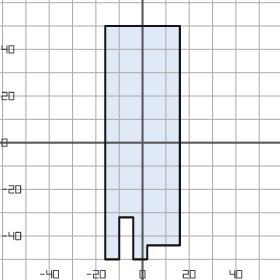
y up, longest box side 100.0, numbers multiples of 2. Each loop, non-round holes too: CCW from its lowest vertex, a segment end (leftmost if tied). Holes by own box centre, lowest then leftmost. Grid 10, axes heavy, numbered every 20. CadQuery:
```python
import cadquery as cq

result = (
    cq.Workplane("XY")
    .moveTo(-16.0, -50.0)
    .lineTo(-10.0, -50.0)
    .lineTo(-10.0, -32.0)
    .lineTo(-4.0, -32.0)
    .lineTo(-4.0, -50.0)
    .lineTo(2.0, -50.0)
    .lineTo(2.0, -44.0)
    .lineTo(16.0, -44.0)
    .lineTo(16.0, 50.0)
    .lineTo(-16.0, 50.0)
    .close()
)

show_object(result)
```